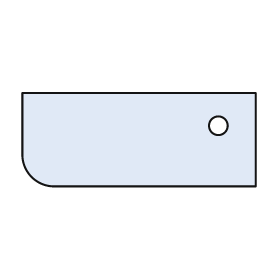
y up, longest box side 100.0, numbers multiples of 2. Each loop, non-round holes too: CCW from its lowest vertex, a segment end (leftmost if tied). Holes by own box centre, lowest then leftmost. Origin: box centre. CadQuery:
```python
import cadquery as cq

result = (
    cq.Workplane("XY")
    .moveTo(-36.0, -20.0)
    .lineTo(50.0, -20.0)
    .lineTo(50.0, 20.0)
    .lineTo(-50.0, 20.0)
    .lineTo(-50.0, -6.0)
    .threePointArc((-46.0, -16.0), (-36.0, -20.0))
    .close()
    .moveTo(34.0, 6.0)
    .circle(4.0)
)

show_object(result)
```